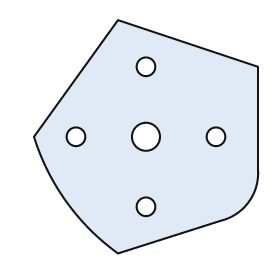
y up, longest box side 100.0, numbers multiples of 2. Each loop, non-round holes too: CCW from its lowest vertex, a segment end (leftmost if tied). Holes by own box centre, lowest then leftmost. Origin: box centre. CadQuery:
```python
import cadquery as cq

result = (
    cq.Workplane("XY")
    .moveTo(-12.0, -50.0)
    .lineTo(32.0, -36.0)
    .threePointArc((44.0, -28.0), (48.0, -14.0))
    .lineTo(48.0, 30.0)
    .lineTo(-12.0, 50.0)
    .lineTo(-48.0, 0.0)
    .threePointArc((-34.0, -28.0), (-12.0, -50.0))
    .close()
    .moveTo(0.0, -30.0)
    .circle(4.0)
    .moveTo(-30.0, 0.0)
    .circle(4.0)
    .moveTo(0.0, 0.0)
    .circle(6.0)
    .moveTo(30.0, 0.0)
    .circle(4.0)
    .moveTo(0.0, 30.0)
    .circle(4.0)
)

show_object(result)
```